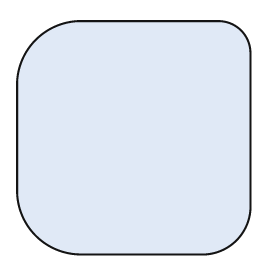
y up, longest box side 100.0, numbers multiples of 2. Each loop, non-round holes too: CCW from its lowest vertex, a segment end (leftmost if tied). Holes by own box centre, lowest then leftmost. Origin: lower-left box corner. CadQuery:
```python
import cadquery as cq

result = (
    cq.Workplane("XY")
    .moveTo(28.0, 0.0)
    .lineTo(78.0, 0.0)
    .threePointArc((94.0, 6.0), (100.0, 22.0))
    .lineTo(100.0, 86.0)
    .threePointArc((96.0, 96.0), (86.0, 100.0))
    .lineTo(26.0, 100.0)
    .threePointArc((8.0, 92.0), (0.0, 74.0))
    .lineTo(0.0, 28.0)
    .threePointArc((8.0, 8.0), (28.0, 0.0))
    .close()
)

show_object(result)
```